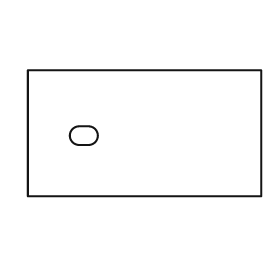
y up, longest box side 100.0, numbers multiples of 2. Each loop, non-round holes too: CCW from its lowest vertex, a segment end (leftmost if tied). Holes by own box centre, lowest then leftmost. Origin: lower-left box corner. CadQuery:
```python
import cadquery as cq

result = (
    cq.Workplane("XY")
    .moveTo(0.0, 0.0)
    .lineTo(100.0, 0.0)
    .lineTo(100.0, 54.0)
    .lineTo(0.0, 54.0)
    .close()
    .moveTo(22.0, 22.0)
    .lineTo(26.0, 22.0)
    .threePointArc((30.0, 26.0), (26.0, 30.0))
    .lineTo(22.0, 30.0)
    .threePointArc((18.0, 26.0), (22.0, 22.0))
    .close()
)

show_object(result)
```